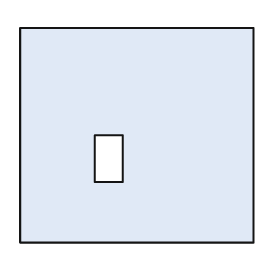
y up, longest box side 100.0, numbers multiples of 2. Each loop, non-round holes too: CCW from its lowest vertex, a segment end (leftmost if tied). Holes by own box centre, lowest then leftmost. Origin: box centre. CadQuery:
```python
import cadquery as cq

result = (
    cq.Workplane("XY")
    .moveTo(-50.0, -46.0)
    .lineTo(50.0, -46.0)
    .lineTo(50.0, 46.0)
    .lineTo(-50.0, 46.0)
    .close()
    .moveTo(-18.0, -20.0)
    .lineTo(-6.0, -20.0)
    .lineTo(-6.0, 0.0)
    .lineTo(-18.0, 0.0)
    .close()
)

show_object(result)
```